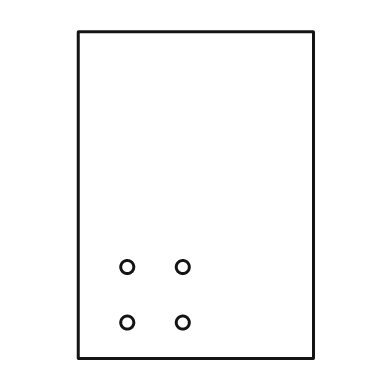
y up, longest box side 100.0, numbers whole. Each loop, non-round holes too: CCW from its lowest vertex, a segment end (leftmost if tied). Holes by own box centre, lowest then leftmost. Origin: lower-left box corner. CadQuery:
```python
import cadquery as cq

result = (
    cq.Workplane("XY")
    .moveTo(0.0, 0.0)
    .lineTo(72.0, 0.0)
    .lineTo(72.0, 100.0)
    .lineTo(0.0, 100.0)
    .close()
    .moveTo(15.0, 11.0)
    .circle(2.0)
    .moveTo(32.0, 11.0)
    .circle(2.0)
    .moveTo(15.0, 28.0)
    .circle(2.0)
    .moveTo(32.0, 28.0)
    .circle(2.0)
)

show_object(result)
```